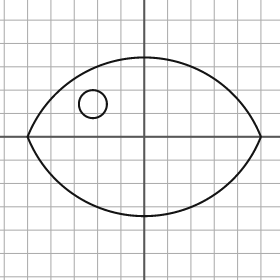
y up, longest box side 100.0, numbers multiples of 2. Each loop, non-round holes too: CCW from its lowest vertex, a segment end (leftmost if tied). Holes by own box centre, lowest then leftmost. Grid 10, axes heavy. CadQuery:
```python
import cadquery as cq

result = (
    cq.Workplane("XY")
    .moveTo(-50.0, 0.0)
    .threePointArc((0.0, -34.0), (50.0, 0.0))
    .threePointArc((0.0, 34.0), (-50.0, 0.0))
    .close()
    .moveTo(-22.0, 14.0)
    .circle(6.0)
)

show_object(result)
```